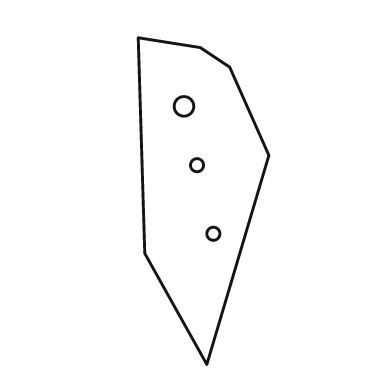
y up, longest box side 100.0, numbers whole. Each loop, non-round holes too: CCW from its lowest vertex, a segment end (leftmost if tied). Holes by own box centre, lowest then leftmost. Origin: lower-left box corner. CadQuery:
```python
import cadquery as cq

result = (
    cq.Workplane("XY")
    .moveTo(21.0, 0.0)
    .lineTo(40.0, 64.0)
    .lineTo(28.0, 91.0)
    .lineTo(19.0, 97.0)
    .lineTo(0.0, 100.0)
    .lineTo(2.0, 34.0)
    .close()
    .moveTo(23.0, 40.0)
    .circle(2.0)
    .moveTo(18.0, 61.0)
    .circle(2.0)
    .moveTo(14.0, 79.0)
    .circle(3.0)
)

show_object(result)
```